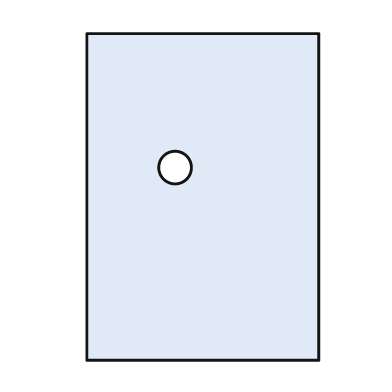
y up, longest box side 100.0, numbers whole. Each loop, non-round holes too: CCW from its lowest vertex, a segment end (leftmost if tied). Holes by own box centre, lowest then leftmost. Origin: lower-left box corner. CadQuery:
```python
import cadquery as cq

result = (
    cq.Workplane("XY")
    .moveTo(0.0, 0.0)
    .lineTo(71.0, 0.0)
    .lineTo(71.0, 100.0)
    .lineTo(0.0, 100.0)
    .close()
    .moveTo(27.0, 59.0)
    .circle(5.0)
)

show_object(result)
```